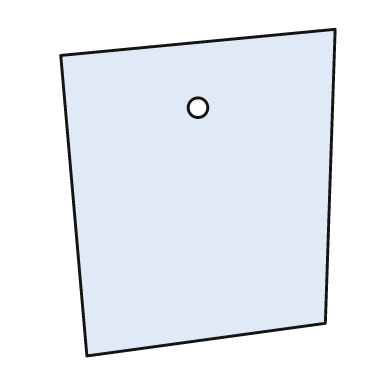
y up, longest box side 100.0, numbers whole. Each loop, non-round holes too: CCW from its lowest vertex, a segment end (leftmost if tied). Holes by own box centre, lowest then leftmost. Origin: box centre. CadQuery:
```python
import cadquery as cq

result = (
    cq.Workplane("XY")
    .moveTo(-34.0, -50.0)
    .lineTo(39.0, -40.0)
    .lineTo(42.0, 50.0)
    .lineTo(-42.0, 42.0)
    .close()
    .moveTo(0.0, 26.0)
    .circle(3.0)
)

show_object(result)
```